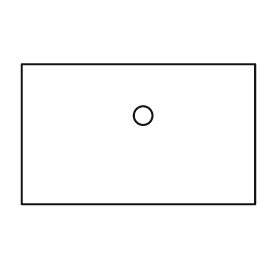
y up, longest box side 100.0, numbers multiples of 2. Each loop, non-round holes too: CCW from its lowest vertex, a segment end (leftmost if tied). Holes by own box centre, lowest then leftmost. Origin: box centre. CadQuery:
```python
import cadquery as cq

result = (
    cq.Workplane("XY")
    .moveTo(-50.0, -30.0)
    .lineTo(50.0, -30.0)
    .lineTo(50.0, 30.0)
    .lineTo(-50.0, 30.0)
    .close()
    .moveTo(2.0, 8.0)
    .circle(4.0)
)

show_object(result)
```